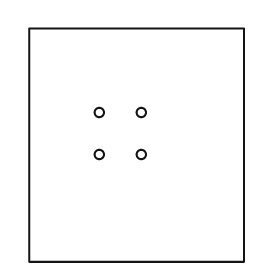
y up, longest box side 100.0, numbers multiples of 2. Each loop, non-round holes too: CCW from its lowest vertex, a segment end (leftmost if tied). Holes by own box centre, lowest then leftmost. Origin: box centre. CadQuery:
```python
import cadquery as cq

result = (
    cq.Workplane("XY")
    .moveTo(-46.0, -50.0)
    .lineTo(46.0, -50.0)
    .lineTo(46.0, 50.0)
    .lineTo(-46.0, 50.0)
    .close()
    .moveTo(-16.0, -4.0)
    .circle(2.0)
    .moveTo(2.0, -4.0)
    .circle(2.0)
    .moveTo(-16.0, 14.0)
    .circle(2.0)
    .moveTo(2.0, 14.0)
    .circle(2.0)
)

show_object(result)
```